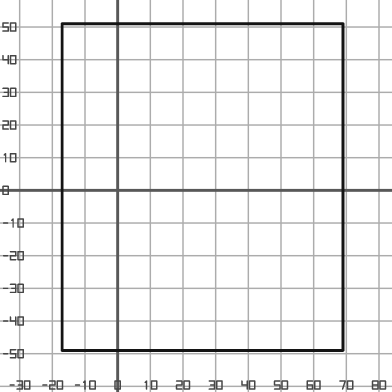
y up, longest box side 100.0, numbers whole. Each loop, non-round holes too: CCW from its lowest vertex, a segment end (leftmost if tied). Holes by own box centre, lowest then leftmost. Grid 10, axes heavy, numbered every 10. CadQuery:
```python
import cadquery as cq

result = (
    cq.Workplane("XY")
    .moveTo(-17.0, -49.0)
    .lineTo(69.0, -49.0)
    .lineTo(69.0, 51.0)
    .lineTo(-17.0, 51.0)
    .close()
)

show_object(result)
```